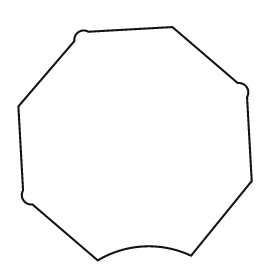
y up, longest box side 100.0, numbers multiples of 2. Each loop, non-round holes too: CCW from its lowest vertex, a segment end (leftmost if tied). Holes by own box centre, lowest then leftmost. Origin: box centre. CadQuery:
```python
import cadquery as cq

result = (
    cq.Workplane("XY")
    .moveTo(-16.0, -50.0)
    .threePointArc((4.0, -44.0), (24.0, -48.0))
    .lineTo(50.0, -16.0)
    .lineTo(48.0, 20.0)
    .threePointArc((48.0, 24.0), (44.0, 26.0))
    .lineTo(16.0, 50.0)
    .lineTo(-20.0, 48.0)
    .threePointArc((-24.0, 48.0), (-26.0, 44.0))
    .lineTo(-50.0, 16.0)
    .lineTo(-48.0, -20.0)
    .threePointArc((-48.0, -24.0), (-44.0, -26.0))
    .close()
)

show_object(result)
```